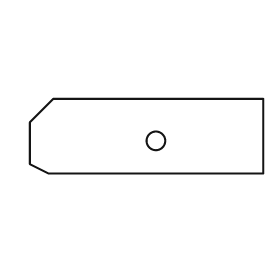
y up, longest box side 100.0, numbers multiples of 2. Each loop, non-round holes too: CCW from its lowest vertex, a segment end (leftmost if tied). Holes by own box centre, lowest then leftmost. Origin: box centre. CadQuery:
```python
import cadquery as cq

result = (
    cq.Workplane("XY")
    .moveTo(-42.0, -16.0)
    .lineTo(50.0, -16.0)
    .lineTo(50.0, 16.0)
    .lineTo(-40.0, 16.0)
    .lineTo(-50.0, 6.0)
    .lineTo(-50.0, -12.0)
    .close()
    .moveTo(4.0, -2.0)
    .circle(4.0)
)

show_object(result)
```